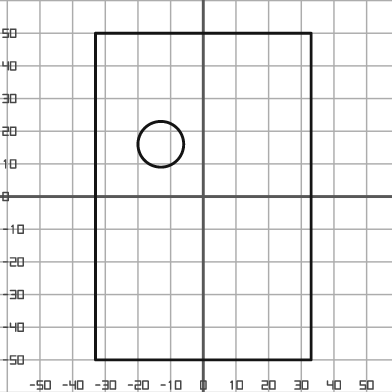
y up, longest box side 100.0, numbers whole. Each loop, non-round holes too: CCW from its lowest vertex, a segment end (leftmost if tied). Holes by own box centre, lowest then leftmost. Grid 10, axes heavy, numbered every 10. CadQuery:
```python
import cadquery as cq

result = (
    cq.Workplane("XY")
    .moveTo(-33.0, -50.0)
    .lineTo(33.0, -50.0)
    .lineTo(33.0, 50.0)
    .lineTo(-33.0, 50.0)
    .close()
    .moveTo(-13.0, 16.0)
    .circle(7.0)
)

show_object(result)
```